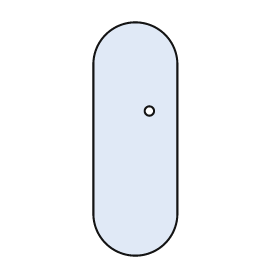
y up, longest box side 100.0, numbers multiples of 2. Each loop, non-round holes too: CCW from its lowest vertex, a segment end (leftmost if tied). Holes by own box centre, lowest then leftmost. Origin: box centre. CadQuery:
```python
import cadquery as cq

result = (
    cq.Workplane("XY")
    .moveTo(-18.0, -32.0)
    .threePointArc((0.0, -50.0), (18.0, -32.0))
    .lineTo(18.0, 32.0)
    .threePointArc((0.0, 50.0), (-18.0, 32.0))
    .close()
    .moveTo(6.0, 12.0)
    .circle(2.0)
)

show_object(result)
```